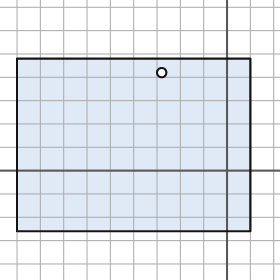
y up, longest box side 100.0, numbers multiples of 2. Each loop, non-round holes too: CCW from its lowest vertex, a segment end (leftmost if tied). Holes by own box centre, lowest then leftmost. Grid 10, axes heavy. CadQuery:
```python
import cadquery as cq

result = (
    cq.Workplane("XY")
    .moveTo(-90.0, -26.0)
    .lineTo(10.0, -26.0)
    .lineTo(10.0, 48.0)
    .lineTo(-90.0, 48.0)
    .close()
    .moveTo(-28.0, 42.0)
    .circle(2.0)
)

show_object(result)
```